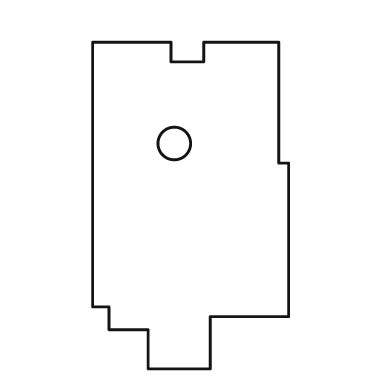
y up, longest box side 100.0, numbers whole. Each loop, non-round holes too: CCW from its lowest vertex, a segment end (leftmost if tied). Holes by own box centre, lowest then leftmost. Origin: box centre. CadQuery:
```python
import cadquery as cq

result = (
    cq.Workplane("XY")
    .moveTo(-13.0, -50.0)
    .lineTo(6.0, -50.0)
    .lineTo(6.0, -34.0)
    .lineTo(30.0, -34.0)
    .lineTo(30.0, 13.0)
    .lineTo(27.0, 13.0)
    .lineTo(27.0, 50.0)
    .lineTo(4.0, 50.0)
    .lineTo(4.0, 44.0)
    .lineTo(-6.0, 44.0)
    .lineTo(-6.0, 50.0)
    .lineTo(-30.0, 50.0)
    .lineTo(-30.0, -31.0)
    .lineTo(-25.0, -31.0)
    .lineTo(-25.0, -38.0)
    .lineTo(-13.0, -38.0)
    .close()
    .moveTo(-5.0, 19.0)
    .circle(5.0)
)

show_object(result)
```